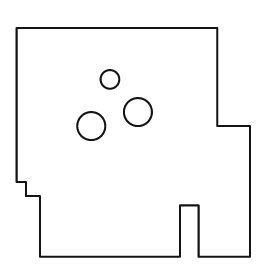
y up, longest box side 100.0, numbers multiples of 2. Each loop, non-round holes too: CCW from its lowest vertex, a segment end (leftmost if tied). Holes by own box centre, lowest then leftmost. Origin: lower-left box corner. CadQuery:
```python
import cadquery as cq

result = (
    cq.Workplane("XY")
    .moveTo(10.0, 0.0)
    .lineTo(70.0, 0.0)
    .lineTo(70.0, 22.0)
    .lineTo(78.0, 22.0)
    .lineTo(78.0, 0.0)
    .lineTo(100.0, 0.0)
    .lineTo(100.0, 56.0)
    .lineTo(86.0, 56.0)
    .lineTo(86.0, 98.0)
    .lineTo(0.0, 98.0)
    .lineTo(0.0, 32.0)
    .lineTo(4.0, 32.0)
    .lineTo(4.0, 26.0)
    .lineTo(10.0, 26.0)
    .close()
    .moveTo(32.0, 56.0)
    .circle(6.0)
    .moveTo(52.0, 62.0)
    .circle(6.0)
    .moveTo(40.0, 76.0)
    .circle(4.0)
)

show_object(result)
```